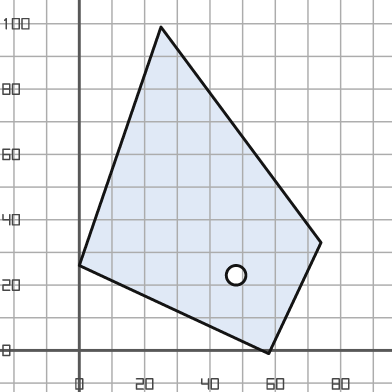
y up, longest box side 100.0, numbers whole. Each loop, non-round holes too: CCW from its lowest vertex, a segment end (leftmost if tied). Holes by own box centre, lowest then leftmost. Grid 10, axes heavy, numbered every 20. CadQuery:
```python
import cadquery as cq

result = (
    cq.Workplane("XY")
    .moveTo(58.0, -1.0)
    .lineTo(74.0, 33.0)
    .lineTo(25.0, 99.0)
    .lineTo(0.0, 26.0)
    .close()
    .moveTo(48.0, 23.0)
    .circle(3.0)
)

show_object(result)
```